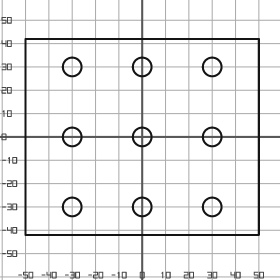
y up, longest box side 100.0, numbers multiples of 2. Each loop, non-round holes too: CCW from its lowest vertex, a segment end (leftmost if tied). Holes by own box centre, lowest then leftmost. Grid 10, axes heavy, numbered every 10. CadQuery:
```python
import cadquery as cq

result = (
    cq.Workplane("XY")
    .moveTo(-50.0, -42.0)
    .lineTo(50.0, -42.0)
    .lineTo(50.0, 42.0)
    .lineTo(-50.0, 42.0)
    .close()
    .moveTo(-30.0, -30.0)
    .circle(4.0)
    .moveTo(0.0, -30.0)
    .circle(4.0)
    .moveTo(30.0, -30.0)
    .circle(4.0)
    .moveTo(-30.0, 0.0)
    .circle(4.0)
    .moveTo(0.0, 0.0)
    .circle(4.0)
    .moveTo(30.0, 0.0)
    .circle(4.0)
    .moveTo(-30.0, 30.0)
    .circle(4.0)
    .moveTo(0.0, 30.0)
    .circle(4.0)
    .moveTo(30.0, 30.0)
    .circle(4.0)
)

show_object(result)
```